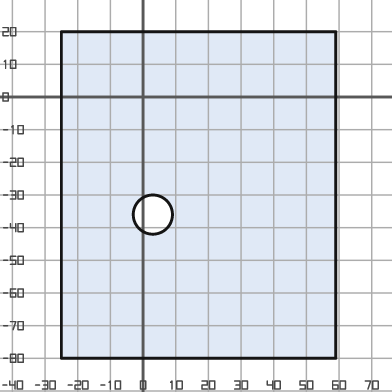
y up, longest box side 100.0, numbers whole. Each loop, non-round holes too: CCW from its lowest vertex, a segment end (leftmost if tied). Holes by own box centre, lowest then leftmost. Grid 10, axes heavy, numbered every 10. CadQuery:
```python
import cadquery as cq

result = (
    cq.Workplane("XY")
    .moveTo(-25.0, -80.0)
    .lineTo(59.0, -80.0)
    .lineTo(59.0, 20.0)
    .lineTo(-25.0, 20.0)
    .close()
    .moveTo(3.0, -36.0)
    .circle(6.0)
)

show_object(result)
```